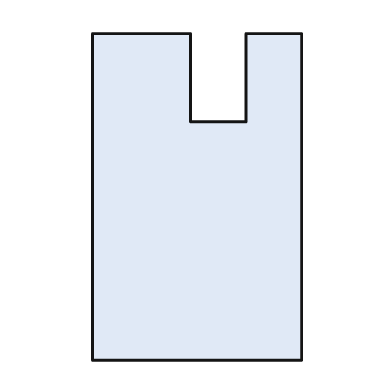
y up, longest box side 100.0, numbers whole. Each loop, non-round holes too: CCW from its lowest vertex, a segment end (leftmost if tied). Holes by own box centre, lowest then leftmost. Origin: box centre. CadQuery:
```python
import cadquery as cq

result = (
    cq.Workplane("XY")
    .moveTo(-32.0, -50.0)
    .lineTo(32.0, -50.0)
    .lineTo(32.0, 50.0)
    .lineTo(15.0, 50.0)
    .lineTo(15.0, 23.0)
    .lineTo(-2.0, 23.0)
    .lineTo(-2.0, 50.0)
    .lineTo(-32.0, 50.0)
    .close()
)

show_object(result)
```